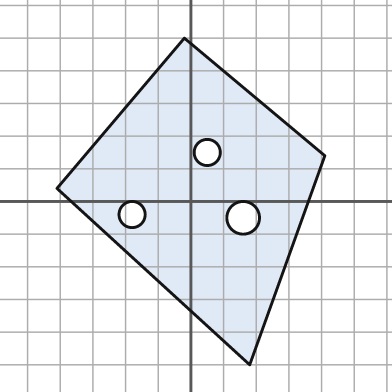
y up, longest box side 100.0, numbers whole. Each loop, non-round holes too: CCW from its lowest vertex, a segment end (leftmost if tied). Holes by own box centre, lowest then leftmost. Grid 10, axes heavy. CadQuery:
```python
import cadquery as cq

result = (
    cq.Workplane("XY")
    .moveTo(18.0, -50.0)
    .lineTo(41.0, 14.0)
    .lineTo(-2.0, 50.0)
    .lineTo(-41.0, 4.0)
    .close()
    .moveTo(16.0, -5.0)
    .circle(5.0)
    .moveTo(-18.0, -4.0)
    .circle(4.0)
    .moveTo(5.0, 15.0)
    .circle(4.0)
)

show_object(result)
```